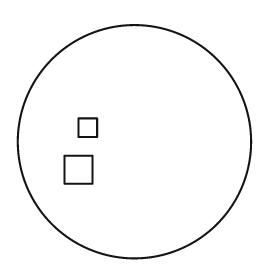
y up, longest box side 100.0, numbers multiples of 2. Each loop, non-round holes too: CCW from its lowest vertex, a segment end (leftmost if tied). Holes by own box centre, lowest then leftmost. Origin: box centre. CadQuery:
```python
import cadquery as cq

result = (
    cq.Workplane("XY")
    .moveTo(0.0, 0.0)
    .circle(50.0)
    .moveTo(-30.0, -18.0)
    .lineTo(-18.0, -18.0)
    .lineTo(-18.0, -6.0)
    .lineTo(-30.0, -6.0)
    .close()
    .moveTo(-24.0, 2.0)
    .lineTo(-16.0, 2.0)
    .lineTo(-16.0, 10.0)
    .lineTo(-24.0, 10.0)
    .close()
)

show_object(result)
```